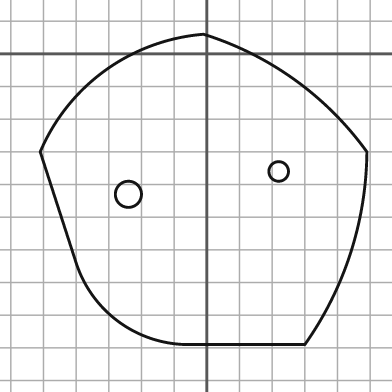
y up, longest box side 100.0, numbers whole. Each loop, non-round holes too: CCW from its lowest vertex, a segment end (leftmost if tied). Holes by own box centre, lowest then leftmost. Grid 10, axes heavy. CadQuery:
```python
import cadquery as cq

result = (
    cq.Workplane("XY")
    .moveTo(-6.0, -89.0)
    .lineTo(30.0, -89.0)
    .threePointArc((44.0, -61.0), (49.0, -30.0))
    .threePointArc((27.0, -8.0), (-1.0, 6.0))
    .threePointArc((-31.0, -5.0), (-51.0, -30.0))
    .lineTo(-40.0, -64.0)
    .threePointArc((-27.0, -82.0), (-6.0, -89.0))
    .close()
    .moveTo(-24.0, -43.0)
    .circle(4.0)
    .moveTo(22.0, -36.0)
    .circle(3.0)
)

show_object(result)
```